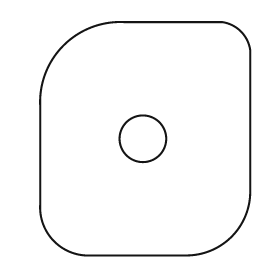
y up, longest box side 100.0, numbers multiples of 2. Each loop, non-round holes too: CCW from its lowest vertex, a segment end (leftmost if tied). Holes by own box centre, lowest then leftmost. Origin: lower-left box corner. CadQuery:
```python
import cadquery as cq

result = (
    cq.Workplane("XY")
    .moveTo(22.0, 0.0)
    .lineTo(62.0, 0.0)
    .threePointArc((82.0, 8.0), (90.0, 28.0))
    .lineTo(90.0, 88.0)
    .threePointArc((86.0, 96.0), (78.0, 100.0))
    .lineTo(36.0, 100.0)
    .threePointArc((10.0, 90.0), (0.0, 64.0))
    .lineTo(0.0, 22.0)
    .threePointArc((6.0, 6.0), (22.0, 0.0))
    .close()
    .moveTo(44.0, 50.0)
    .circle(10.0)
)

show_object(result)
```